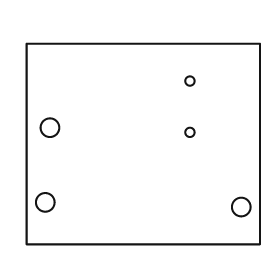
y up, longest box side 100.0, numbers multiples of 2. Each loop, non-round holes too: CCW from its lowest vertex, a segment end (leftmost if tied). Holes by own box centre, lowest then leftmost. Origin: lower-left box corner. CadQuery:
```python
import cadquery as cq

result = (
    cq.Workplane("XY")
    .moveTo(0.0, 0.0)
    .lineTo(100.0, 0.0)
    .lineTo(100.0, 86.0)
    .lineTo(0.0, 86.0)
    .close()
    .moveTo(92.0, 16.0)
    .circle(4.0)
    .moveTo(8.0, 18.0)
    .circle(4.0)
    .moveTo(70.0, 48.0)
    .circle(2.0)
    .moveTo(10.0, 50.0)
    .circle(4.0)
    .moveTo(70.0, 70.0)
    .circle(2.0)
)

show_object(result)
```